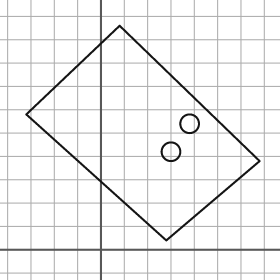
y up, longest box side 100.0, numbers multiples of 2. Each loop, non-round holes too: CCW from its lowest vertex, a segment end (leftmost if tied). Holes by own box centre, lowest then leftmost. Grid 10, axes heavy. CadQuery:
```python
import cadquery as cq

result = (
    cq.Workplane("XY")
    .moveTo(28.0, 4.0)
    .lineTo(68.0, 38.0)
    .lineTo(8.0, 96.0)
    .lineTo(-32.0, 58.0)
    .close()
    .moveTo(30.0, 42.0)
    .circle(4.0)
    .moveTo(38.0, 54.0)
    .circle(4.0)
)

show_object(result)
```